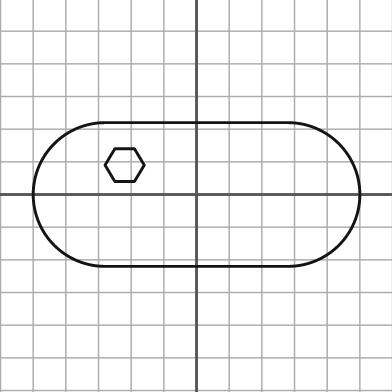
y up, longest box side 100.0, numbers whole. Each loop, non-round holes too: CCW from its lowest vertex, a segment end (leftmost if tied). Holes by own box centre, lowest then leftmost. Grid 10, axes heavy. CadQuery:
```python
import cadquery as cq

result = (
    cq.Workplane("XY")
    .moveTo(-28.0, -22.0)
    .lineTo(28.0, -22.0)
    .threePointArc((50.0, 0.0), (28.0, 22.0))
    .lineTo(-28.0, 22.0)
    .threePointArc((-50.0, 0.0), (-28.0, -22.0))
    .close()
    .moveTo(-25.0, 4.0)
    .lineTo(-19.0, 4.0)
    .lineTo(-16.0, 9.0)
    .lineTo(-19.0, 14.0)
    .lineTo(-25.0, 14.0)
    .lineTo(-28.0, 9.0)
    .close()
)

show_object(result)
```